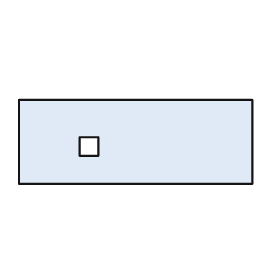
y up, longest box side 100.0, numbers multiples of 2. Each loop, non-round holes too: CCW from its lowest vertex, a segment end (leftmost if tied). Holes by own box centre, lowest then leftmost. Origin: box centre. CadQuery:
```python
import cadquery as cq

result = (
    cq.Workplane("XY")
    .moveTo(-50.0, -18.0)
    .lineTo(50.0, -18.0)
    .lineTo(50.0, 18.0)
    .lineTo(-50.0, 18.0)
    .close()
    .moveTo(-24.0, -6.0)
    .lineTo(-16.0, -6.0)
    .lineTo(-16.0, 2.0)
    .lineTo(-24.0, 2.0)
    .close()
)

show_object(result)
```